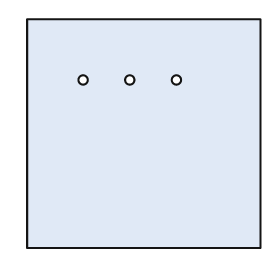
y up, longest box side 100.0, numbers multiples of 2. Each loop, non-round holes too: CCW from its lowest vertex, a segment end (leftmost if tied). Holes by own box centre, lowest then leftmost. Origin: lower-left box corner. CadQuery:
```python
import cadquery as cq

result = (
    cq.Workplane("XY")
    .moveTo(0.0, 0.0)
    .lineTo(100.0, 0.0)
    .lineTo(100.0, 98.0)
    .lineTo(0.0, 98.0)
    .close()
    .moveTo(24.0, 72.0)
    .circle(2.0)
    .moveTo(44.0, 72.0)
    .circle(2.0)
    .moveTo(64.0, 72.0)
    .circle(2.0)
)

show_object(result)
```